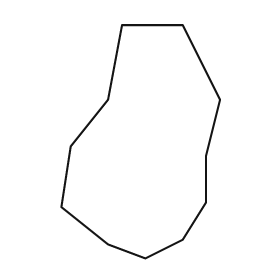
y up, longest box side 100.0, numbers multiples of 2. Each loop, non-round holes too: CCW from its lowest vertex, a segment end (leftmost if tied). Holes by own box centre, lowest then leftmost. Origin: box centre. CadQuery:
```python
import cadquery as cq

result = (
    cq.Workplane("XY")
    .moveTo(2.0, -50.0)
    .lineTo(18.0, -42.0)
    .lineTo(28.0, -26.0)
    .lineTo(28.0, -6.0)
    .lineTo(34.0, 18.0)
    .lineTo(18.0, 50.0)
    .lineTo(-8.0, 50.0)
    .lineTo(-14.0, 18.0)
    .lineTo(-30.0, -2.0)
    .lineTo(-34.0, -28.0)
    .lineTo(-14.0, -44.0)
    .close()
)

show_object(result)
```